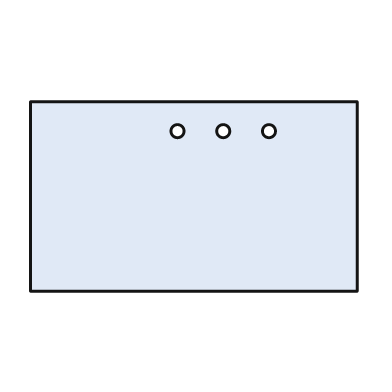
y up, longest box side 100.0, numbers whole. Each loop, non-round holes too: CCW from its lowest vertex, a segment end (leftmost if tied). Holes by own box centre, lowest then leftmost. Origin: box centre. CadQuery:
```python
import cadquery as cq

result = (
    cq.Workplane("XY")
    .moveTo(-50.0, -29.0)
    .lineTo(50.0, -29.0)
    .lineTo(50.0, 29.0)
    .lineTo(-50.0, 29.0)
    .close()
    .moveTo(-5.0, 20.0)
    .circle(2.0)
    .moveTo(9.0, 20.0)
    .circle(2.0)
    .moveTo(23.0, 20.0)
    .circle(2.0)
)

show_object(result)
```